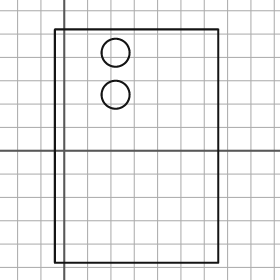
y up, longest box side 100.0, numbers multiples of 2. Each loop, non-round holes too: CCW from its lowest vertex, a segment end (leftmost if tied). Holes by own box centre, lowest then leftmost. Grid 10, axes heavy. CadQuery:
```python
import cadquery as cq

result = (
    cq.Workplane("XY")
    .moveTo(-4.0, -48.0)
    .lineTo(66.0, -48.0)
    .lineTo(66.0, 52.0)
    .lineTo(-4.0, 52.0)
    .close()
    .moveTo(22.0, 24.0)
    .circle(6.0)
    .moveTo(22.0, 42.0)
    .circle(6.0)
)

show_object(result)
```